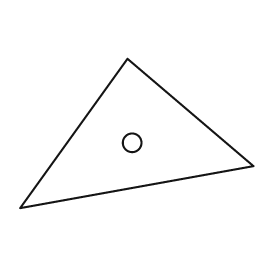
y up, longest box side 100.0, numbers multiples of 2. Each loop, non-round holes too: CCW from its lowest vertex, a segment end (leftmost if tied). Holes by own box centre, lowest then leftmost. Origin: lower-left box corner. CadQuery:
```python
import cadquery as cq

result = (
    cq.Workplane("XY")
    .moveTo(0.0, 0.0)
    .lineTo(100.0, 18.0)
    .lineTo(46.0, 64.0)
    .close()
    .moveTo(48.0, 28.0)
    .circle(4.0)
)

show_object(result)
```